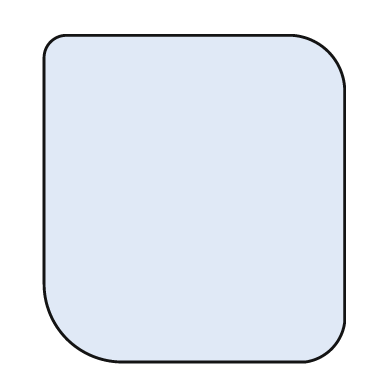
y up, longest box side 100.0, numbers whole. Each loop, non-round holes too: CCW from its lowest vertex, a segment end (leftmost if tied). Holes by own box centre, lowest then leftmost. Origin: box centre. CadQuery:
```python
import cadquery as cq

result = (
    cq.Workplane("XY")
    .moveTo(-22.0, -50.0)
    .lineTo(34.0, -50.0)
    .threePointArc((42.0, -46.0), (46.0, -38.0))
    .lineTo(46.0, 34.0)
    .threePointArc((41.0, 45.0), (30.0, 50.0))
    .lineTo(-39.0, 50.0)
    .threePointArc((-44.0, 48.0), (-46.0, 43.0))
    .lineTo(-46.0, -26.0)
    .threePointArc((-39.0, -43.0), (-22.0, -50.0))
    .close()
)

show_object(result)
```